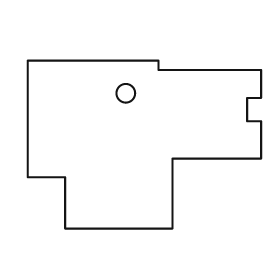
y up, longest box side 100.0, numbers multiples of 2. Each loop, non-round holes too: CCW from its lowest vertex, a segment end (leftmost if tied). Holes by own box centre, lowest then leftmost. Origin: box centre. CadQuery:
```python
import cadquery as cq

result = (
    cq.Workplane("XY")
    .moveTo(-34.0, -36.0)
    .lineTo(12.0, -36.0)
    .lineTo(12.0, -6.0)
    .lineTo(50.0, -6.0)
    .lineTo(50.0, 10.0)
    .lineTo(44.0, 10.0)
    .lineTo(44.0, 20.0)
    .lineTo(50.0, 20.0)
    .lineTo(50.0, 32.0)
    .lineTo(6.0, 32.0)
    .lineTo(6.0, 36.0)
    .lineTo(-50.0, 36.0)
    .lineTo(-50.0, -14.0)
    .lineTo(-34.0, -14.0)
    .close()
    .moveTo(-8.0, 22.0)
    .circle(4.0)
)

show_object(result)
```